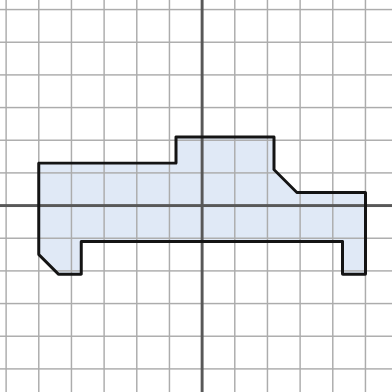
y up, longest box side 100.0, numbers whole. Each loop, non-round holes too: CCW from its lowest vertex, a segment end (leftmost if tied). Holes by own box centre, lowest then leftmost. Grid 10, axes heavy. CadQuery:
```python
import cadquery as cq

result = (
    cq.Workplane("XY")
    .moveTo(-44.0, -21.0)
    .lineTo(-37.0, -21.0)
    .lineTo(-37.0, -11.0)
    .lineTo(43.0, -11.0)
    .lineTo(43.0, -21.0)
    .lineTo(50.0, -21.0)
    .lineTo(50.0, 4.0)
    .lineTo(29.0, 4.0)
    .lineTo(22.0, 11.0)
    .lineTo(22.0, 21.0)
    .lineTo(-8.0, 21.0)
    .lineTo(-8.0, 13.0)
    .lineTo(-50.0, 13.0)
    .lineTo(-50.0, -15.0)
    .close()
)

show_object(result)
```